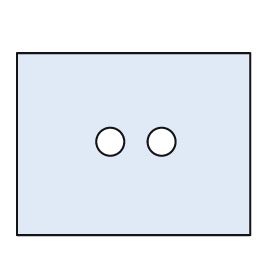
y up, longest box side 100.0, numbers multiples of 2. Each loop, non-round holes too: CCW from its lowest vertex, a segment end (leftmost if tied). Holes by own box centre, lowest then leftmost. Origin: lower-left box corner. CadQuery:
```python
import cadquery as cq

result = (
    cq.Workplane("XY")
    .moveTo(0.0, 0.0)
    .lineTo(100.0, 0.0)
    .lineTo(100.0, 78.0)
    .lineTo(0.0, 78.0)
    .close()
    .moveTo(40.0, 40.0)
    .circle(6.0)
    .moveTo(62.0, 40.0)
    .circle(6.0)
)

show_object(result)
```